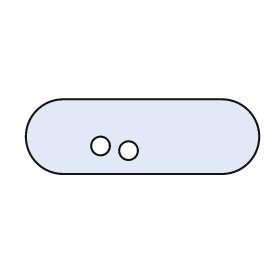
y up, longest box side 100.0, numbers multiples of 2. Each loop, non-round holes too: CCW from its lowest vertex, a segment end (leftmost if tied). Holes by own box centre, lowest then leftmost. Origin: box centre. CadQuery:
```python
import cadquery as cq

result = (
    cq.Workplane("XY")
    .moveTo(-34.0, -16.0)
    .lineTo(34.0, -16.0)
    .threePointArc((50.0, 0.0), (34.0, 16.0))
    .lineTo(-34.0, 16.0)
    .threePointArc((-50.0, 0.0), (-34.0, -16.0))
    .close()
    .moveTo(-6.0, -6.0)
    .circle(4.0)
    .moveTo(-18.0, -4.0)
    .circle(4.0)
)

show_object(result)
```